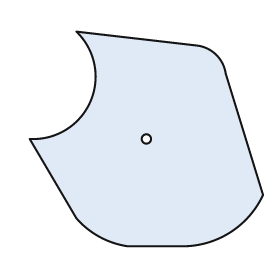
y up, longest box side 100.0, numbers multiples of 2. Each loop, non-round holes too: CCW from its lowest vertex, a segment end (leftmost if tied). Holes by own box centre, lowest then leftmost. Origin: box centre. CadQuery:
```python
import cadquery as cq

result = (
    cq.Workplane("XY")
    .moveTo(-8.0, -46.0)
    .lineTo(16.0, -46.0)
    .threePointArc((36.0, -40.0), (50.0, -24.0))
    .lineTo(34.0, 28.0)
    .threePointArc((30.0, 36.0), (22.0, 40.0))
    .lineTo(-30.0, 46.0)
    .threePointArc((-24.0, 16.0), (-50.0, 0.0))
    .lineTo(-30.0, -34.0)
    .threePointArc((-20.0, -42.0), (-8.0, -46.0))
    .close()
    .moveTo(0.0, 0.0)
    .circle(2.0)
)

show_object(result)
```